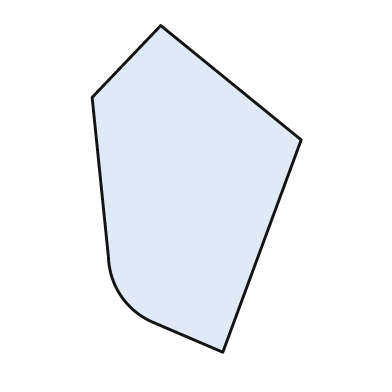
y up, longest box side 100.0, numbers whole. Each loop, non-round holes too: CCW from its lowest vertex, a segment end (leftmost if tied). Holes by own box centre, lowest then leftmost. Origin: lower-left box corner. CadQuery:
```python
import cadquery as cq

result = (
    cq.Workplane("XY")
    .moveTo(40.0, 0.0)
    .lineTo(64.0, 65.0)
    .lineTo(21.0, 100.0)
    .lineTo(0.0, 78.0)
    .lineTo(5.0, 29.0)
    .threePointArc((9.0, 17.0), (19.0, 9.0))
    .close()
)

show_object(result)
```